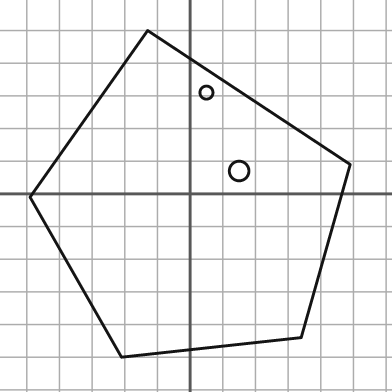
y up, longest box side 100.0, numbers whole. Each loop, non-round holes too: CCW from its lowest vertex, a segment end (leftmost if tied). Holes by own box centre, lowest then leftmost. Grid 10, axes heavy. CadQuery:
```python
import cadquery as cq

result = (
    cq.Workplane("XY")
    .moveTo(-21.0, -50.0)
    .lineTo(34.0, -44.0)
    .lineTo(49.0, 9.0)
    .lineTo(-13.0, 50.0)
    .lineTo(-49.0, -1.0)
    .close()
    .moveTo(15.0, 7.0)
    .circle(3.0)
    .moveTo(5.0, 31.0)
    .circle(2.0)
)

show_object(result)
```